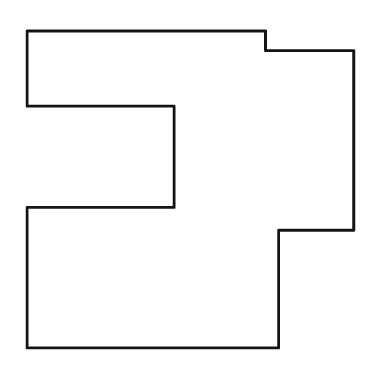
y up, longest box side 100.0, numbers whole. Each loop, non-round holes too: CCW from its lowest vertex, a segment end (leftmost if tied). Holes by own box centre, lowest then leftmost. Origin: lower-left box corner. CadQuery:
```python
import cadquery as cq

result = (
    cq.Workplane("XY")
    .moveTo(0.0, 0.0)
    .lineTo(77.0, 0.0)
    .lineTo(77.0, 36.0)
    .lineTo(100.0, 36.0)
    .lineTo(100.0, 91.0)
    .lineTo(73.0, 91.0)
    .lineTo(73.0, 97.0)
    .lineTo(0.0, 97.0)
    .lineTo(0.0, 74.0)
    .lineTo(45.0, 74.0)
    .lineTo(45.0, 43.0)
    .lineTo(0.0, 43.0)
    .close()
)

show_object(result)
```